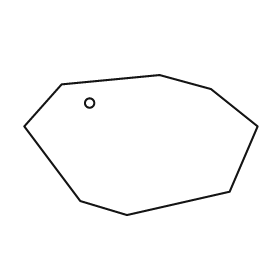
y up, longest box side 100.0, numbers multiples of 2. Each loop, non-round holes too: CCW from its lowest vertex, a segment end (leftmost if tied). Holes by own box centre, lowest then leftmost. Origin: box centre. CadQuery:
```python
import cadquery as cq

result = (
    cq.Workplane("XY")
    .moveTo(-6.0, -30.0)
    .lineTo(38.0, -20.0)
    .lineTo(50.0, 8.0)
    .lineTo(30.0, 24.0)
    .lineTo(8.0, 30.0)
    .lineTo(-34.0, 26.0)
    .lineTo(-50.0, 8.0)
    .lineTo(-26.0, -24.0)
    .close()
    .moveTo(-22.0, 18.0)
    .circle(2.0)
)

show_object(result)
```